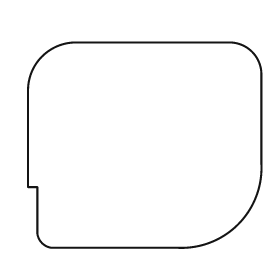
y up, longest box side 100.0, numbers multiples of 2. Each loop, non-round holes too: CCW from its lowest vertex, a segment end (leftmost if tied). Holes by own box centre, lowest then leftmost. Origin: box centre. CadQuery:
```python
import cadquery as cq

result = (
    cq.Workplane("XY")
    .moveTo(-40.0, -44.0)
    .lineTo(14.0, -44.0)
    .threePointArc((40.0, -34.0), (50.0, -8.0))
    .lineTo(50.0, 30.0)
    .threePointArc((46.0, 40.0), (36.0, 44.0))
    .lineTo(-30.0, 44.0)
    .threePointArc((-44.0, 38.0), (-50.0, 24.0))
    .lineTo(-50.0, -18.0)
    .lineTo(-46.0, -18.0)
    .lineTo(-46.0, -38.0)
    .threePointArc((-44.0, -42.0), (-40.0, -44.0))
    .close()
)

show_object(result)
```